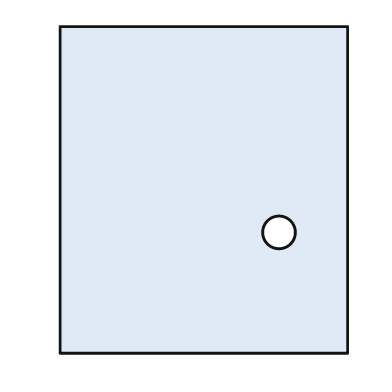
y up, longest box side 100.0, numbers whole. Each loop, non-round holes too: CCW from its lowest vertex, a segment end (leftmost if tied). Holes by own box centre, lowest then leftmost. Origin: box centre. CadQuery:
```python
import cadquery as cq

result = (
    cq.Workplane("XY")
    .moveTo(-44.0, -50.0)
    .lineTo(44.0, -50.0)
    .lineTo(44.0, 50.0)
    .lineTo(-44.0, 50.0)
    .close()
    .moveTo(23.0, -13.0)
    .circle(5.0)
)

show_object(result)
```